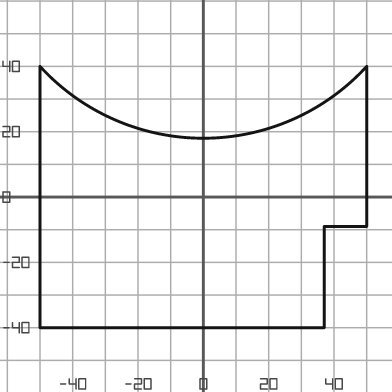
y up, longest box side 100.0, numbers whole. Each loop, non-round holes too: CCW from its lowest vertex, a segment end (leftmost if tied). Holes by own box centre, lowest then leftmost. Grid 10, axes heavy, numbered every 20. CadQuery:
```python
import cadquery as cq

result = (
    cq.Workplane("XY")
    .moveTo(-50.0, -40.0)
    .lineTo(37.0, -40.0)
    .lineTo(37.0, -9.0)
    .lineTo(50.0, -9.0)
    .lineTo(50.0, 40.0)
    .threePointArc((0.0, 18.0), (-50.0, 40.0))
    .close()
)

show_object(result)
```